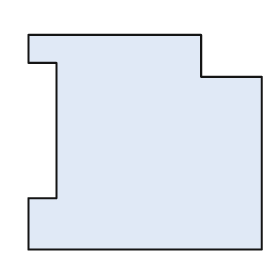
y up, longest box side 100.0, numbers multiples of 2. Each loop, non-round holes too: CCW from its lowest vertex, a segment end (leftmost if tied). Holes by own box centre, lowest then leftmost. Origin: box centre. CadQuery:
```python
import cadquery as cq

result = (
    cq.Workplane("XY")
    .moveTo(-50.0, -46.0)
    .lineTo(50.0, -46.0)
    .lineTo(50.0, 28.0)
    .lineTo(24.0, 28.0)
    .lineTo(24.0, 46.0)
    .lineTo(-50.0, 46.0)
    .lineTo(-50.0, 34.0)
    .lineTo(-38.0, 34.0)
    .lineTo(-38.0, -24.0)
    .lineTo(-50.0, -24.0)
    .close()
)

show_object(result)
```